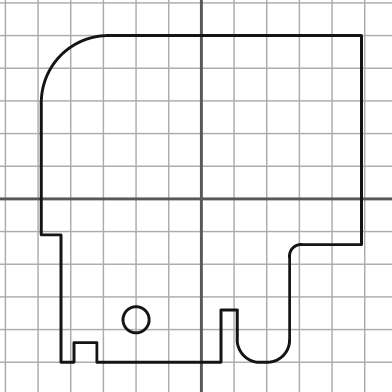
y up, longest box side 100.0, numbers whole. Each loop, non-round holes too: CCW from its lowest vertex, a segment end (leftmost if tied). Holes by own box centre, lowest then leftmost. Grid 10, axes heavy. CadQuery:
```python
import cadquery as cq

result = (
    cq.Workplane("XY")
    .moveTo(-43.0, -50.0)
    .lineTo(-39.0, -50.0)
    .lineTo(-39.0, -44.0)
    .lineTo(-32.0, -44.0)
    .lineTo(-32.0, -50.0)
    .lineTo(6.0, -50.0)
    .lineTo(6.0, -34.0)
    .lineTo(11.0, -34.0)
    .lineTo(11.0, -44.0)
    .threePointArc((13.0, -48.0), (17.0, -50.0))
    .lineTo(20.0, -50.0)
    .threePointArc((25.0, -48.0), (27.0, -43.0))
    .lineTo(27.0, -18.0)
    .threePointArc((28.0, -15.0), (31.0, -14.0))
    .lineTo(49.0, -14.0)
    .lineTo(49.0, 50.0)
    .lineTo(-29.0, 50.0)
    .threePointArc((-43.0, 44.0), (-49.0, 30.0))
    .lineTo(-49.0, -11.0)
    .lineTo(-43.0, -11.0)
    .close()
    .moveTo(-20.0, -37.0)
    .circle(4.0)
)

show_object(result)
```